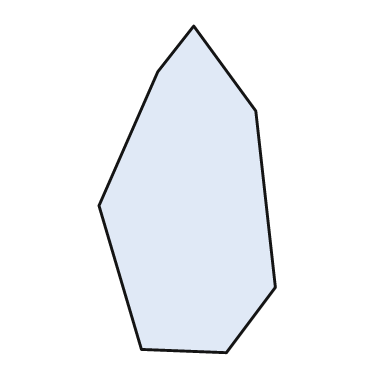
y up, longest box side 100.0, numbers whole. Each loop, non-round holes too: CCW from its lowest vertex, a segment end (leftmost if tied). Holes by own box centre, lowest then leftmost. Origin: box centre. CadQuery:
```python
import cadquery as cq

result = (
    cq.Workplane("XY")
    .moveTo(12.0, -50.0)
    .lineTo(27.0, -30.0)
    .lineTo(21.0, 24.0)
    .lineTo(2.0, 50.0)
    .lineTo(-9.0, 36.0)
    .lineTo(-27.0, -5.0)
    .lineTo(-14.0, -49.0)
    .close()
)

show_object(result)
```